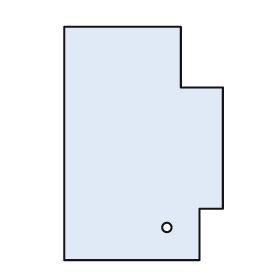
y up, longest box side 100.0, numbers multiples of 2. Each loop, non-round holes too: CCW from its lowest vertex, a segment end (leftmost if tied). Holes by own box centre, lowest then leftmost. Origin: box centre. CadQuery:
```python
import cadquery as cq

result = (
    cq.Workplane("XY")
    .moveTo(-34.0, -50.0)
    .lineTo(24.0, -50.0)
    .lineTo(24.0, -28.0)
    .lineTo(34.0, -28.0)
    .lineTo(34.0, 24.0)
    .lineTo(16.0, 24.0)
    .lineTo(16.0, 50.0)
    .lineTo(-34.0, 50.0)
    .close()
    .moveTo(10.0, -36.0)
    .circle(2.0)
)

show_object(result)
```